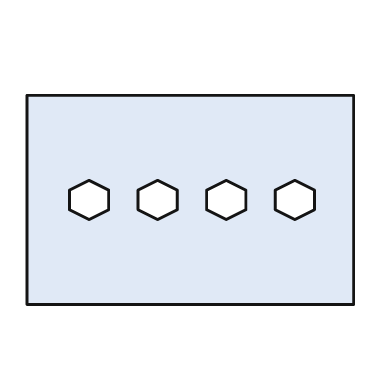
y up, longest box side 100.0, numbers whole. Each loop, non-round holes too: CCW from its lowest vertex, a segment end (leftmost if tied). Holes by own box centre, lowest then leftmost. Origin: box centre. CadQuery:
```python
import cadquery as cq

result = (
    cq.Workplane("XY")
    .moveTo(-50.0, -32.0)
    .lineTo(50.0, -32.0)
    .lineTo(50.0, 32.0)
    .lineTo(-50.0, 32.0)
    .close()
    .moveTo(-31.0, -6.0)
    .lineTo(-25.0, -3.0)
    .lineTo(-25.0, 3.0)
    .lineTo(-31.0, 6.0)
    .lineTo(-37.0, 3.0)
    .lineTo(-37.0, -3.0)
    .close()
    .moveTo(-10.0, -6.0)
    .lineTo(-4.0, -3.0)
    .lineTo(-4.0, 3.0)
    .lineTo(-10.0, 6.0)
    .lineTo(-16.0, 3.0)
    .lineTo(-16.0, -3.0)
    .close()
    .moveTo(11.0, -6.0)
    .lineTo(17.0, -3.0)
    .lineTo(17.0, 3.0)
    .lineTo(11.0, 6.0)
    .lineTo(5.0, 3.0)
    .lineTo(5.0, -3.0)
    .close()
    .moveTo(32.0, -6.0)
    .lineTo(38.0, -3.0)
    .lineTo(38.0, 3.0)
    .lineTo(32.0, 6.0)
    .lineTo(26.0, 3.0)
    .lineTo(26.0, -3.0)
    .close()
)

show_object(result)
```